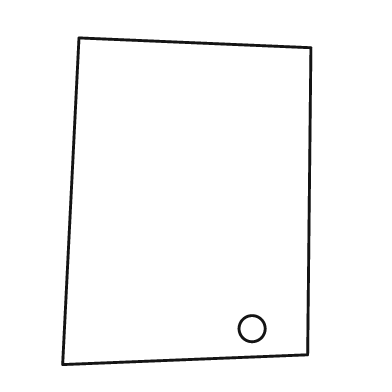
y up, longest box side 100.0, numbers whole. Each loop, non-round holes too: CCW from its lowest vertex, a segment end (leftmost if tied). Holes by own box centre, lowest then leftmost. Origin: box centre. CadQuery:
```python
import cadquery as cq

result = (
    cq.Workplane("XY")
    .moveTo(-38.0, -50.0)
    .lineTo(37.0, -47.0)
    .lineTo(38.0, 47.0)
    .lineTo(-33.0, 50.0)
    .close()
    .moveTo(20.0, -39.0)
    .circle(4.0)
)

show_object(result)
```